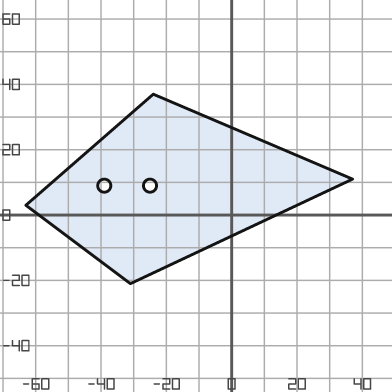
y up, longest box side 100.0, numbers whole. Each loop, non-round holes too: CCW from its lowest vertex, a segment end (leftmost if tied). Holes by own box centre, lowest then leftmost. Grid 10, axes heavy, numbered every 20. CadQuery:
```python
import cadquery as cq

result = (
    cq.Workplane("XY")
    .moveTo(-31.0, -21.0)
    .lineTo(37.0, 11.0)
    .lineTo(-24.0, 37.0)
    .lineTo(-63.0, 3.0)
    .close()
    .moveTo(-39.0, 9.0)
    .circle(2.0)
    .moveTo(-25.0, 9.0)
    .circle(2.0)
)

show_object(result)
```